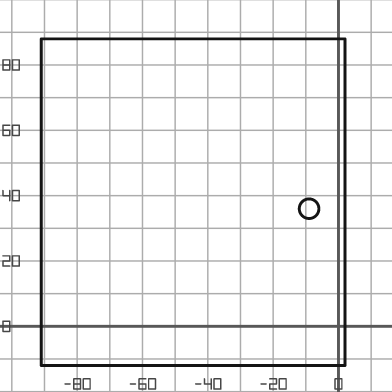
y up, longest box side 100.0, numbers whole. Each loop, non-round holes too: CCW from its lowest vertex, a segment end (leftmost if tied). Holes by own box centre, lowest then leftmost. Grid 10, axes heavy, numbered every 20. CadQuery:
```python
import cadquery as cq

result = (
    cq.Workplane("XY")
    .moveTo(-91.0, -12.0)
    .lineTo(2.0, -12.0)
    .lineTo(2.0, 88.0)
    .lineTo(-91.0, 88.0)
    .close()
    .moveTo(-9.0, 36.0)
    .circle(3.0)
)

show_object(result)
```